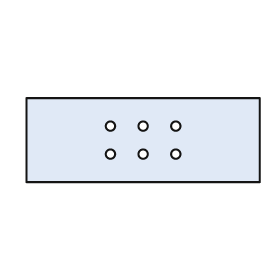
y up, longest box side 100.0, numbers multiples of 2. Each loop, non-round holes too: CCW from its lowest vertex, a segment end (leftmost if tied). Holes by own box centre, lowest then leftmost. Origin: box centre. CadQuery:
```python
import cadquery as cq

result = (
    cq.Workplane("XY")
    .moveTo(-50.0, -18.0)
    .lineTo(50.0, -18.0)
    .lineTo(50.0, 18.0)
    .lineTo(-50.0, 18.0)
    .close()
    .moveTo(-14.0, -6.0)
    .circle(2.0)
    .moveTo(0.0, -6.0)
    .circle(2.0)
    .moveTo(14.0, -6.0)
    .circle(2.0)
    .moveTo(-14.0, 6.0)
    .circle(2.0)
    .moveTo(0.0, 6.0)
    .circle(2.0)
    .moveTo(14.0, 6.0)
    .circle(2.0)
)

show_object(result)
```